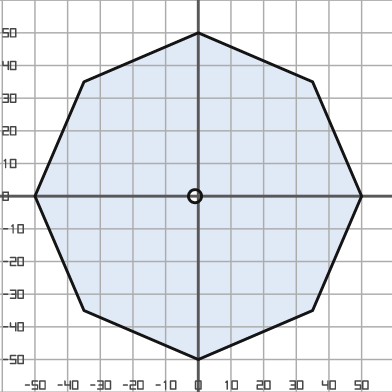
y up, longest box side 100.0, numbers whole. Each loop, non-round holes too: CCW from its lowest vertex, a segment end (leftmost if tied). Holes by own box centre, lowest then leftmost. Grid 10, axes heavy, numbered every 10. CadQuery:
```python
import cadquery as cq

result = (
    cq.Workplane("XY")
    .moveTo(0.0, -50.0)
    .lineTo(35.0, -35.0)
    .lineTo(50.0, 0.0)
    .lineTo(35.0, 35.0)
    .lineTo(0.0, 50.0)
    .lineTo(-35.0, 35.0)
    .lineTo(-50.0, 0.0)
    .lineTo(-35.0, -35.0)
    .close()
    .moveTo(-1.0, 0.0)
    .circle(2.0)
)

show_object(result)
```